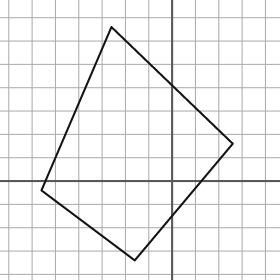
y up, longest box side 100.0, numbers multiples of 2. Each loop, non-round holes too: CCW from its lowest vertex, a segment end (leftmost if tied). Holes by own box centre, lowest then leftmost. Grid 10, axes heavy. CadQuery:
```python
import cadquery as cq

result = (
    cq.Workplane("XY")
    .moveTo(-16.0, -34.0)
    .lineTo(26.0, 16.0)
    .lineTo(-26.0, 66.0)
    .lineTo(-56.0, -4.0)
    .close()
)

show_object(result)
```